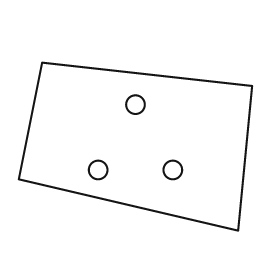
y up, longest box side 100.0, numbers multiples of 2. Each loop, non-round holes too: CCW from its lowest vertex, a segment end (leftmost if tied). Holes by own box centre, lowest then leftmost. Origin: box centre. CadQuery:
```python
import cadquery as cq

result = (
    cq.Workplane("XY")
    .moveTo(44.0, -36.0)
    .lineTo(50.0, 26.0)
    .lineTo(-40.0, 36.0)
    .lineTo(-50.0, -14.0)
    .close()
    .moveTo(-16.0, -10.0)
    .circle(4.0)
    .moveTo(16.0, -10.0)
    .circle(4.0)
    .moveTo(0.0, 18.0)
    .circle(4.0)
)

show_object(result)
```